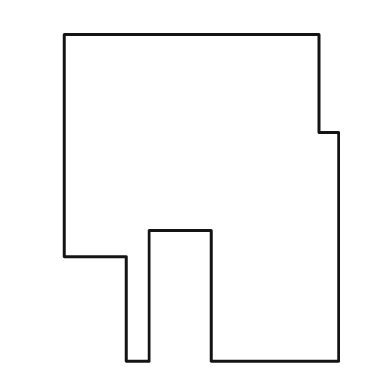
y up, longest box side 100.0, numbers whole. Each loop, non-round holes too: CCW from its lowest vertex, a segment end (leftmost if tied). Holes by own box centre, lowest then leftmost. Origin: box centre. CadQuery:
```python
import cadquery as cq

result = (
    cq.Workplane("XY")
    .moveTo(-23.0, -50.0)
    .lineTo(-16.0, -50.0)
    .lineTo(-16.0, -10.0)
    .lineTo(3.0, -10.0)
    .lineTo(3.0, -50.0)
    .lineTo(42.0, -50.0)
    .lineTo(42.0, 20.0)
    .lineTo(36.0, 20.0)
    .lineTo(36.0, 50.0)
    .lineTo(-42.0, 50.0)
    .lineTo(-42.0, -18.0)
    .lineTo(-23.0, -18.0)
    .close()
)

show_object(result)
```